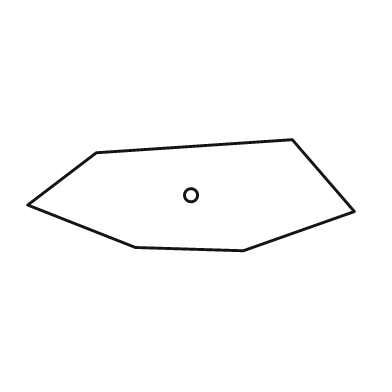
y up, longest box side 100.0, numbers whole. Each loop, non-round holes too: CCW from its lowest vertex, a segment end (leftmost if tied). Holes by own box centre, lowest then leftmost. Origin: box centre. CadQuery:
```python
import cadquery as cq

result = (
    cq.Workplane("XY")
    .moveTo(16.0, -17.0)
    .lineTo(50.0, -5.0)
    .lineTo(31.0, 17.0)
    .lineTo(-29.0, 13.0)
    .lineTo(-50.0, -3.0)
    .lineTo(-17.0, -16.0)
    .close()
    .moveTo(0.0, 0.0)
    .circle(2.0)
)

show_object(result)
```